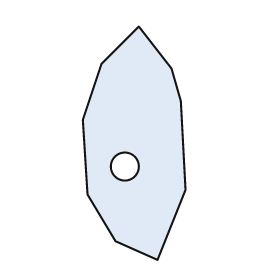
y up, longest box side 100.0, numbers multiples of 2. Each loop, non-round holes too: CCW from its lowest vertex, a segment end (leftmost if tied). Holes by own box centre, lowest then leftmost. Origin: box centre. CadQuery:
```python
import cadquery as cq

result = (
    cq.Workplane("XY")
    .moveTo(10.0, -50.0)
    .lineTo(22.0, -20.0)
    .lineTo(20.0, 18.0)
    .lineTo(16.0, 32.0)
    .lineTo(2.0, 50.0)
    .lineTo(-14.0, 34.0)
    .lineTo(-22.0, 10.0)
    .lineTo(-20.0, -22.0)
    .lineTo(-8.0, -42.0)
    .close()
    .moveTo(-4.0, -10.0)
    .circle(6.0)
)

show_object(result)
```